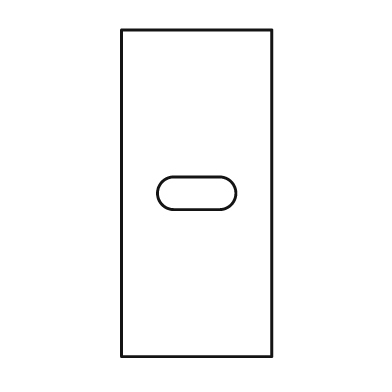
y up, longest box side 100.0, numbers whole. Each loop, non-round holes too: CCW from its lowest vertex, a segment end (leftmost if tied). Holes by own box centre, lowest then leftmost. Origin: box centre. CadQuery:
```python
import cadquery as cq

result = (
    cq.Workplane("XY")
    .moveTo(-23.0, -50.0)
    .lineTo(23.0, -50.0)
    .lineTo(23.0, 50.0)
    .lineTo(-23.0, 50.0)
    .close()
    .moveTo(-7.0, -5.0)
    .lineTo(7.0, -5.0)
    .threePointArc((12.0, 0.0), (7.0, 5.0))
    .lineTo(-7.0, 5.0)
    .threePointArc((-12.0, 0.0), (-7.0, -5.0))
    .close()
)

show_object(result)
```